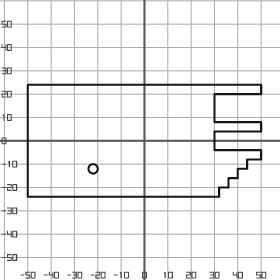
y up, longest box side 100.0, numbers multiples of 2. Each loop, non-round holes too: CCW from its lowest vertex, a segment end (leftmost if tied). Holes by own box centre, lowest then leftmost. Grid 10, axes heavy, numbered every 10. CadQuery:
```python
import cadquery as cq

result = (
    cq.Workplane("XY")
    .moveTo(-50.0, -24.0)
    .lineTo(32.0, -24.0)
    .lineTo(32.0, -20.0)
    .lineTo(36.0, -20.0)
    .lineTo(36.0, -16.0)
    .lineTo(40.0, -16.0)
    .lineTo(40.0, -12.0)
    .lineTo(44.0, -12.0)
    .lineTo(44.0, -8.0)
    .lineTo(50.0, -8.0)
    .lineTo(50.0, -4.0)
    .lineTo(30.0, -4.0)
    .lineTo(30.0, 4.0)
    .lineTo(50.0, 4.0)
    .lineTo(50.0, 8.0)
    .lineTo(30.0, 8.0)
    .lineTo(30.0, 20.0)
    .lineTo(50.0, 20.0)
    .lineTo(50.0, 24.0)
    .lineTo(-50.0, 24.0)
    .close()
    .moveTo(-22.0, -12.0)
    .circle(2.0)
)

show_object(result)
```